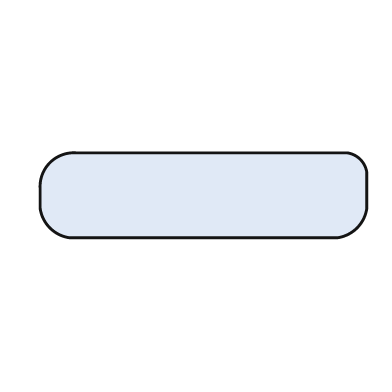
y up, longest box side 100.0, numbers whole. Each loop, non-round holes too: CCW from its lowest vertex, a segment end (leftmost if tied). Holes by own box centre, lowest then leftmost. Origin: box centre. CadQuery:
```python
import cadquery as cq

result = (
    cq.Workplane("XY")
    .moveTo(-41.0, -13.0)
    .lineTo(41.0, -13.0)
    .threePointArc((47.0, -10.0), (50.0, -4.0))
    .lineTo(50.0, 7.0)
    .threePointArc((48.0, 11.0), (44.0, 13.0))
    .lineTo(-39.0, 13.0)
    .threePointArc((-47.0, 10.0), (-50.0, 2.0))
    .lineTo(-50.0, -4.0)
    .threePointArc((-47.0, -10.0), (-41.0, -13.0))
    .close()
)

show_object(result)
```